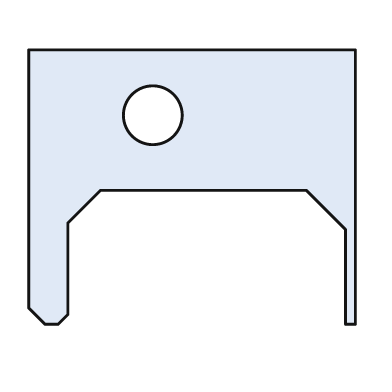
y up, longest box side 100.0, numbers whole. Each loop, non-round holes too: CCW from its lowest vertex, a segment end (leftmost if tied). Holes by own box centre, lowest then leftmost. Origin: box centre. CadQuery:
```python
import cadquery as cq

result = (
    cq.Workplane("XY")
    .moveTo(-45.0, -42.0)
    .lineTo(-41.0, -42.0)
    .lineTo(-38.0, -39.0)
    .lineTo(-38.0, -11.0)
    .lineTo(-28.0, -1.0)
    .lineTo(35.0, -1.0)
    .lineTo(47.0, -13.0)
    .lineTo(47.0, -42.0)
    .lineTo(50.0, -42.0)
    .lineTo(50.0, 42.0)
    .lineTo(-50.0, 42.0)
    .lineTo(-50.0, -37.0)
    .close()
    .moveTo(-12.0, 22.0)
    .circle(9.0)
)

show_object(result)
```